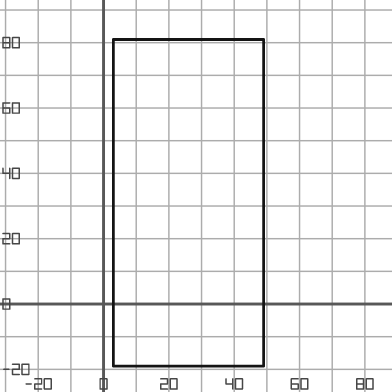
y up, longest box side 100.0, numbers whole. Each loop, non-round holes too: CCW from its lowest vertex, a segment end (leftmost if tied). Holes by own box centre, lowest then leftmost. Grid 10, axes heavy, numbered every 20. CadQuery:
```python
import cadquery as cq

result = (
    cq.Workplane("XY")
    .moveTo(3.0, -19.0)
    .lineTo(49.0, -19.0)
    .lineTo(49.0, 81.0)
    .lineTo(3.0, 81.0)
    .close()
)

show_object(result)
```